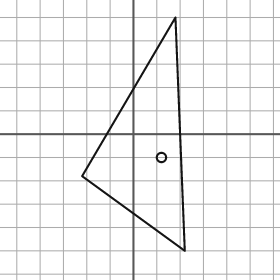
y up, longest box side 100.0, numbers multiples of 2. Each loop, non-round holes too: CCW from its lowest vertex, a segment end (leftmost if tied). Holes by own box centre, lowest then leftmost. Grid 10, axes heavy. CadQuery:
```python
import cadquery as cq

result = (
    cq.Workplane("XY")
    .moveTo(22.0, -50.0)
    .lineTo(18.0, 50.0)
    .lineTo(-22.0, -18.0)
    .close()
    .moveTo(12.0, -10.0)
    .circle(2.0)
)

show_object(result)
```